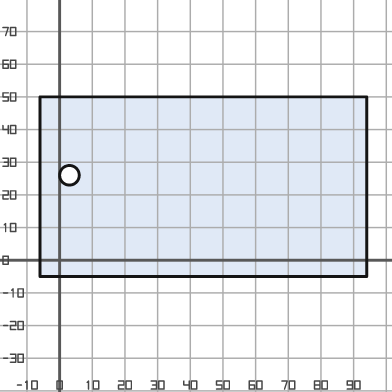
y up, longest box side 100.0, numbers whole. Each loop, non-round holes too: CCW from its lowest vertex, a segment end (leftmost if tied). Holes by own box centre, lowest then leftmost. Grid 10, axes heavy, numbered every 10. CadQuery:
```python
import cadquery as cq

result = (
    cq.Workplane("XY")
    .moveTo(-6.0, -5.0)
    .lineTo(94.0, -5.0)
    .lineTo(94.0, 50.0)
    .lineTo(-6.0, 50.0)
    .close()
    .moveTo(3.0, 26.0)
    .circle(3.0)
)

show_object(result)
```